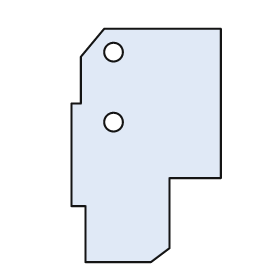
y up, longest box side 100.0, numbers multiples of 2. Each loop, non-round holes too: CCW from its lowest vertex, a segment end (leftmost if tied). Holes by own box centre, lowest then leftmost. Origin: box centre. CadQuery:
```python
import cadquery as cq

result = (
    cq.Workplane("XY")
    .moveTo(-26.0, -50.0)
    .lineTo(2.0, -50.0)
    .lineTo(10.0, -44.0)
    .lineTo(10.0, -14.0)
    .lineTo(32.0, -14.0)
    .lineTo(32.0, 50.0)
    .lineTo(-18.0, 50.0)
    .lineTo(-28.0, 38.0)
    .lineTo(-28.0, 18.0)
    .lineTo(-32.0, 18.0)
    .lineTo(-32.0, -26.0)
    .lineTo(-26.0, -26.0)
    .close()
    .moveTo(-14.0, 10.0)
    .circle(4.0)
    .moveTo(-14.0, 40.0)
    .circle(4.0)
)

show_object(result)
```